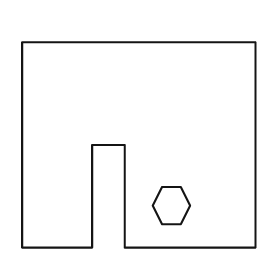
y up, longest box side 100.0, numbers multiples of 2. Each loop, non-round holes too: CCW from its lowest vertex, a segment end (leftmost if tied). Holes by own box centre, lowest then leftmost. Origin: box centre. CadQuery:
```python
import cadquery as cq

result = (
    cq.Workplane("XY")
    .moveTo(-50.0, -44.0)
    .lineTo(-20.0, -44.0)
    .lineTo(-20.0, 0.0)
    .lineTo(-6.0, 0.0)
    .lineTo(-6.0, -44.0)
    .lineTo(50.0, -44.0)
    .lineTo(50.0, 44.0)
    .lineTo(-50.0, 44.0)
    .close()
    .moveTo(10.0, -34.0)
    .lineTo(18.0, -34.0)
    .lineTo(22.0, -26.0)
    .lineTo(18.0, -18.0)
    .lineTo(10.0, -18.0)
    .lineTo(6.0, -26.0)
    .close()
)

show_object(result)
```